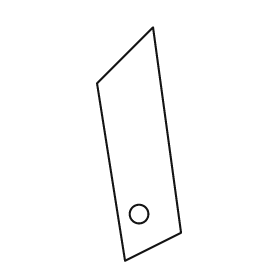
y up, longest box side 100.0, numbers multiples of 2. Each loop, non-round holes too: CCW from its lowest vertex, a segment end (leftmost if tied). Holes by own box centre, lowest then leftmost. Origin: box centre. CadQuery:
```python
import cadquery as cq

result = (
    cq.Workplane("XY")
    .moveTo(-6.0, -50.0)
    .lineTo(18.0, -38.0)
    .lineTo(6.0, 50.0)
    .lineTo(-18.0, 26.0)
    .close()
    .moveTo(0.0, -30.0)
    .circle(4.0)
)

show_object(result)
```